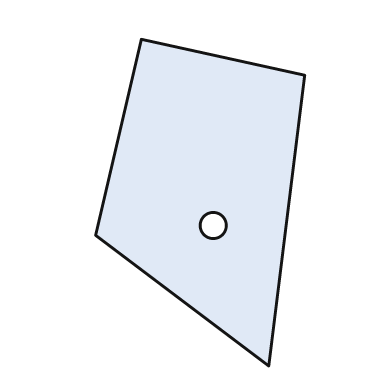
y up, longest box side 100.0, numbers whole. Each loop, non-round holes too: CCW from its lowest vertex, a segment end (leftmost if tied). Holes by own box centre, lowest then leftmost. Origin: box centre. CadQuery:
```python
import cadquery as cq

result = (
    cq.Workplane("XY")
    .moveTo(21.0, -50.0)
    .lineTo(32.0, 39.0)
    .lineTo(-18.0, 50.0)
    .lineTo(-32.0, -10.0)
    .close()
    .moveTo(4.0, -7.0)
    .circle(4.0)
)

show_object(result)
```